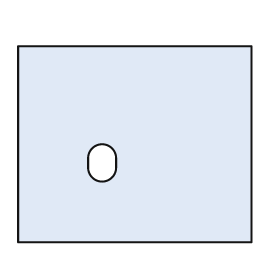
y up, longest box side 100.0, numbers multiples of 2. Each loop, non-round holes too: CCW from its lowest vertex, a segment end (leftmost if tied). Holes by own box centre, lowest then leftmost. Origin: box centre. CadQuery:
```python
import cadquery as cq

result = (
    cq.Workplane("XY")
    .moveTo(-50.0, -42.0)
    .lineTo(50.0, -42.0)
    .lineTo(50.0, 42.0)
    .lineTo(-50.0, 42.0)
    .close()
    .moveTo(-20.0, -10.0)
    .threePointArc((-14.0, -16.0), (-8.0, -10.0))
    .lineTo(-8.0, -6.0)
    .threePointArc((-14.0, 0.0), (-20.0, -6.0))
    .close()
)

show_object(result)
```